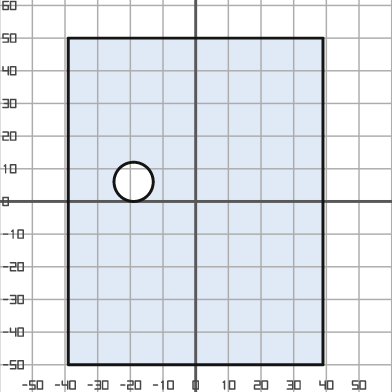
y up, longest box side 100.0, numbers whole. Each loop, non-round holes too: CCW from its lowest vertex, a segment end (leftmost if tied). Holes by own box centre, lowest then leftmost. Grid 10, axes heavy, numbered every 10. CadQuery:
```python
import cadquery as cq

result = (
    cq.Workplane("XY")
    .moveTo(-39.0, -50.0)
    .lineTo(39.0, -50.0)
    .lineTo(39.0, 50.0)
    .lineTo(-39.0, 50.0)
    .close()
    .moveTo(-19.0, 6.0)
    .circle(6.0)
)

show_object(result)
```